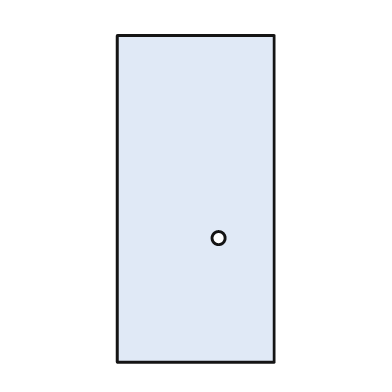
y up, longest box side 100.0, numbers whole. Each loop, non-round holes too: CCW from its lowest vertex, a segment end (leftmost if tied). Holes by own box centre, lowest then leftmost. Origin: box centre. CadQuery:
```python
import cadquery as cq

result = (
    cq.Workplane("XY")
    .moveTo(-24.0, -50.0)
    .lineTo(24.0, -50.0)
    .lineTo(24.0, 50.0)
    .lineTo(-24.0, 50.0)
    .close()
    .moveTo(7.0, -12.0)
    .circle(2.0)
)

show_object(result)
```